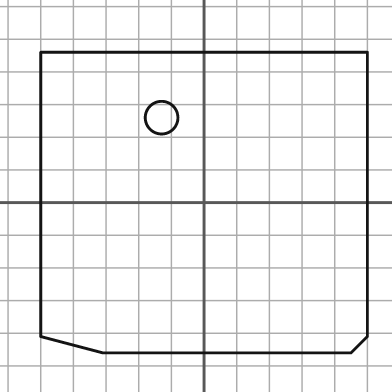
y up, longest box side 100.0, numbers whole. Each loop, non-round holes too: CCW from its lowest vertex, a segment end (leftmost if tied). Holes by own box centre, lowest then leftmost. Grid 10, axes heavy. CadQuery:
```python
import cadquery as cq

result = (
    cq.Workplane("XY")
    .moveTo(-31.0, -46.0)
    .lineTo(45.0, -46.0)
    .lineTo(50.0, -41.0)
    .lineTo(50.0, 46.0)
    .lineTo(-50.0, 46.0)
    .lineTo(-50.0, -41.0)
    .close()
    .moveTo(-13.0, 26.0)
    .circle(5.0)
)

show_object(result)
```